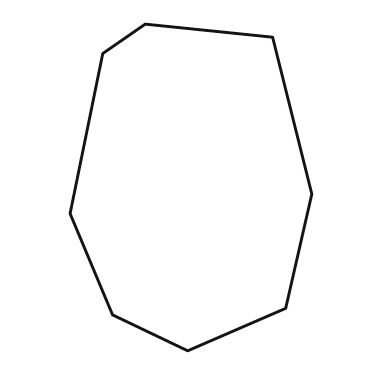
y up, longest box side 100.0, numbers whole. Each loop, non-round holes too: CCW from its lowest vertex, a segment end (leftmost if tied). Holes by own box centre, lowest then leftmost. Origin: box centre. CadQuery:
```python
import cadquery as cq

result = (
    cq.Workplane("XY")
    .moveTo(-1.0, -50.0)
    .lineTo(29.0, -37.0)
    .lineTo(37.0, -2.0)
    .lineTo(25.0, 46.0)
    .lineTo(-14.0, 50.0)
    .lineTo(-27.0, 41.0)
    .lineTo(-37.0, -8.0)
    .lineTo(-24.0, -39.0)
    .close()
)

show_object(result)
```